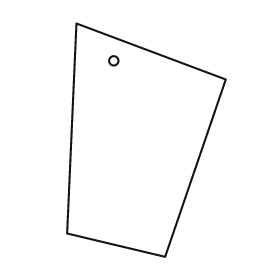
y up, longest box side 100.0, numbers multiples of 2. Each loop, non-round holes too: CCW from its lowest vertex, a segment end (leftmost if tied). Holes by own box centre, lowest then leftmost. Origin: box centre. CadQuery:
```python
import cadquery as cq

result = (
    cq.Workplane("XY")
    .moveTo(8.0, -50.0)
    .lineTo(34.0, 26.0)
    .lineTo(-30.0, 50.0)
    .lineTo(-34.0, -40.0)
    .close()
    .moveTo(-14.0, 34.0)
    .circle(2.0)
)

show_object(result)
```